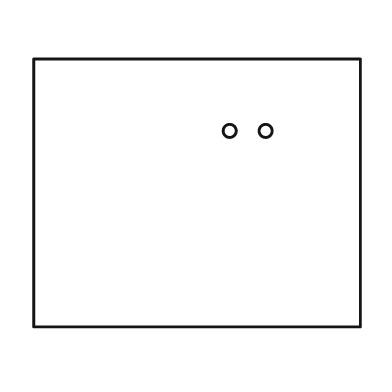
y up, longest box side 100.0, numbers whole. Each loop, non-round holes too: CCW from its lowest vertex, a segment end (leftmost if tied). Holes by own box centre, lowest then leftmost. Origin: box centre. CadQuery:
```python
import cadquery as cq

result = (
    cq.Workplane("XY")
    .moveTo(-50.0, -41.0)
    .lineTo(50.0, -41.0)
    .lineTo(50.0, 41.0)
    .lineTo(-50.0, 41.0)
    .close()
    .moveTo(10.0, 19.0)
    .circle(2.0)
    .moveTo(21.0, 19.0)
    .circle(2.0)
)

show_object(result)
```